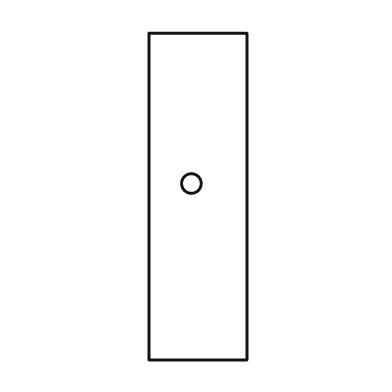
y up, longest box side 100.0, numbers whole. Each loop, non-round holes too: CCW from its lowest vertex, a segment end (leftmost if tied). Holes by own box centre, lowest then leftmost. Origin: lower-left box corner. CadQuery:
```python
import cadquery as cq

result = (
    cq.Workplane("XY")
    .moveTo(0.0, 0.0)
    .lineTo(30.0, 0.0)
    .lineTo(30.0, 100.0)
    .lineTo(0.0, 100.0)
    .close()
    .moveTo(13.0, 54.0)
    .circle(3.0)
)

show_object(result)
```